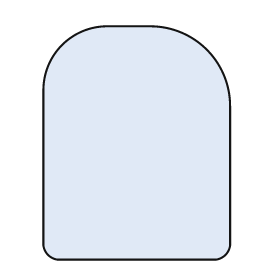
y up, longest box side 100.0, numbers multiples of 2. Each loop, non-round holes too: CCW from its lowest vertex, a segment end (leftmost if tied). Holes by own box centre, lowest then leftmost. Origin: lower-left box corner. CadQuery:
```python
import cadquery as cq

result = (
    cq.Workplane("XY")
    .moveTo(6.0, 0.0)
    .lineTo(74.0, 0.0)
    .threePointArc((78.0, 2.0), (80.0, 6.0))
    .lineTo(80.0, 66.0)
    .threePointArc((70.0, 90.0), (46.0, 100.0))
    .lineTo(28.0, 100.0)
    .threePointArc((8.0, 92.0), (0.0, 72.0))
    .lineTo(0.0, 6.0)
    .threePointArc((2.0, 2.0), (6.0, 0.0))
    .close()
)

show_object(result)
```